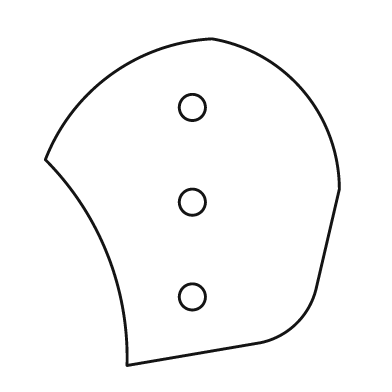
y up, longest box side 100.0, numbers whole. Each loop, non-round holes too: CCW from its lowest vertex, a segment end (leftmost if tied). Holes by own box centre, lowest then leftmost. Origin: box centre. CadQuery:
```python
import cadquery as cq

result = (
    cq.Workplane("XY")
    .moveTo(-20.0, -50.0)
    .lineTo(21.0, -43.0)
    .threePointArc((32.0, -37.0), (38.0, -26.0))
    .lineTo(45.0, 4.0)
    .threePointArc((34.0, 34.0), (6.0, 50.0))
    .threePointArc((-25.0, 39.0), (-45.0, 13.0))
    .threePointArc((-26.0, -16.0), (-20.0, -50.0))
    .close()
    .moveTo(0.0, -29.0)
    .circle(4.0)
    .moveTo(0.0, 0.0)
    .circle(4.0)
    .moveTo(0.0, 29.0)
    .circle(4.0)
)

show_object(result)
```